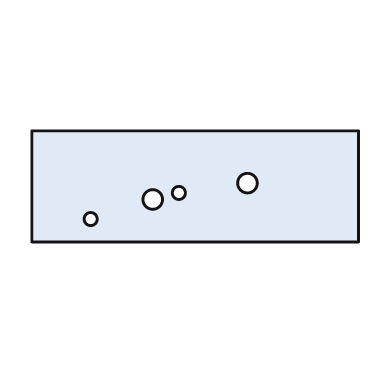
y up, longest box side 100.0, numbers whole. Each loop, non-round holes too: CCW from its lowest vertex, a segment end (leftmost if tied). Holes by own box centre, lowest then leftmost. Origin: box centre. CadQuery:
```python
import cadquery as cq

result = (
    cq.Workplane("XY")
    .moveTo(-50.0, -17.0)
    .lineTo(50.0, -17.0)
    .lineTo(50.0, 17.0)
    .lineTo(-50.0, 17.0)
    .close()
    .moveTo(-32.0, -10.0)
    .circle(2.0)
    .moveTo(-13.0, -4.0)
    .circle(3.0)
    .moveTo(-5.0, -2.0)
    .circle(2.0)
    .moveTo(16.0, 1.0)
    .circle(3.0)
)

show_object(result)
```